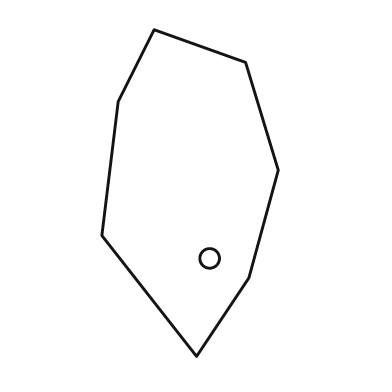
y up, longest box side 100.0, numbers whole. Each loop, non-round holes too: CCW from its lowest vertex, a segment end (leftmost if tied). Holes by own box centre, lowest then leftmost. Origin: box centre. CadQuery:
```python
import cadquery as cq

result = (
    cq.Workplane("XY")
    .moveTo(2.0, -50.0)
    .lineTo(18.0, -26.0)
    .lineTo(27.0, 7.0)
    .lineTo(17.0, 40.0)
    .lineTo(-11.0, 50.0)
    .lineTo(-22.0, 28.0)
    .lineTo(-27.0, -13.0)
    .close()
    .moveTo(6.0, -20.0)
    .circle(3.0)
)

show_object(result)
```